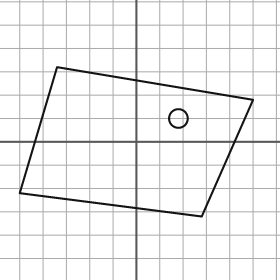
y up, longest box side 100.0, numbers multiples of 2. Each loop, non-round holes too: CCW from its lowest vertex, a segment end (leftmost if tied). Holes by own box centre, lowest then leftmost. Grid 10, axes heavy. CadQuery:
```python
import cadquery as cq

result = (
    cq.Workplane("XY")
    .moveTo(28.0, -32.0)
    .lineTo(50.0, 18.0)
    .lineTo(-34.0, 32.0)
    .lineTo(-50.0, -22.0)
    .close()
    .moveTo(18.0, 10.0)
    .circle(4.0)
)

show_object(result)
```